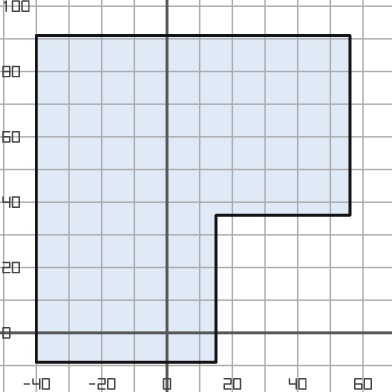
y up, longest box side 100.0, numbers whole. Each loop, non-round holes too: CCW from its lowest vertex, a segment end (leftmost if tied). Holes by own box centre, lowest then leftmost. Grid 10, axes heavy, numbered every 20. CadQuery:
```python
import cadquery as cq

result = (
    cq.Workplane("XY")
    .moveTo(-40.0, -9.0)
    .lineTo(15.0, -9.0)
    .lineTo(15.0, 36.0)
    .lineTo(56.0, 36.0)
    .lineTo(56.0, 91.0)
    .lineTo(-40.0, 91.0)
    .close()
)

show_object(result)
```